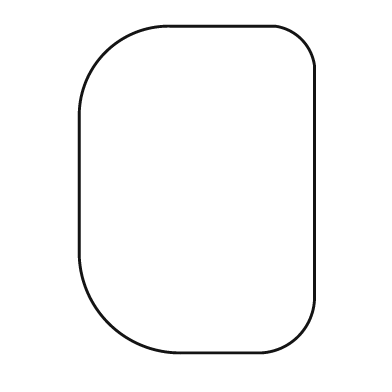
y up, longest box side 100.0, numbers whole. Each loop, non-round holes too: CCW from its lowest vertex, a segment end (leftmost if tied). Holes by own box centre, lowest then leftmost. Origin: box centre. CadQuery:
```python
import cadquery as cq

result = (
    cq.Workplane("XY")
    .moveTo(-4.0, -50.0)
    .lineTo(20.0, -50.0)
    .threePointArc((31.0, -45.0), (36.0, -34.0))
    .lineTo(36.0, 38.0)
    .threePointArc((32.0, 46.0), (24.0, 50.0))
    .lineTo(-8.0, 50.0)
    .threePointArc((-28.0, 42.0), (-36.0, 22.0))
    .lineTo(-36.0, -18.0)
    .threePointArc((-27.0, -41.0), (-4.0, -50.0))
    .close()
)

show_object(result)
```